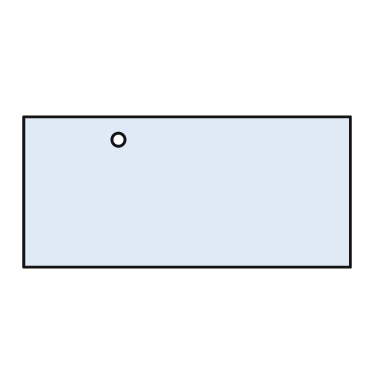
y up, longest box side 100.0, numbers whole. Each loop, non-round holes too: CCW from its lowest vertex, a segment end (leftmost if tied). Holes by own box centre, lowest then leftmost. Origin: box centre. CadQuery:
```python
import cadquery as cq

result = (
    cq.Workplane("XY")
    .moveTo(-50.0, -23.0)
    .lineTo(50.0, -23.0)
    .lineTo(50.0, 23.0)
    .lineTo(-50.0, 23.0)
    .close()
    .moveTo(-21.0, 16.0)
    .circle(2.0)
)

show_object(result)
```